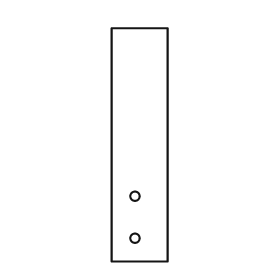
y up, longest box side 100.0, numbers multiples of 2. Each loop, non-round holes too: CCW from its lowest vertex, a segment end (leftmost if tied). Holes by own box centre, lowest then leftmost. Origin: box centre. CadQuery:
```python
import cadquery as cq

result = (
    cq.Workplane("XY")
    .moveTo(-12.0, -50.0)
    .lineTo(12.0, -50.0)
    .lineTo(12.0, 50.0)
    .lineTo(-12.0, 50.0)
    .close()
    .moveTo(-2.0, -40.0)
    .circle(2.0)
    .moveTo(-2.0, -22.0)
    .circle(2.0)
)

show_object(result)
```